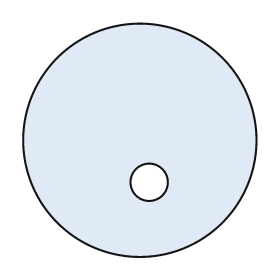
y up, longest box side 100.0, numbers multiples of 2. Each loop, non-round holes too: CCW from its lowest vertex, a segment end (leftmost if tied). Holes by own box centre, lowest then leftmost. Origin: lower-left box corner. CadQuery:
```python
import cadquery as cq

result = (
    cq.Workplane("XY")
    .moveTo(50.0, 50.0)
    .circle(50.0)
    .moveTo(54.0, 32.0)
    .circle(8.0)
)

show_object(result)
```